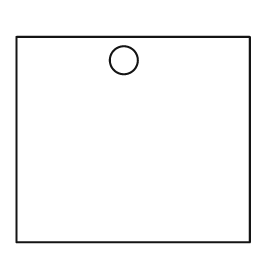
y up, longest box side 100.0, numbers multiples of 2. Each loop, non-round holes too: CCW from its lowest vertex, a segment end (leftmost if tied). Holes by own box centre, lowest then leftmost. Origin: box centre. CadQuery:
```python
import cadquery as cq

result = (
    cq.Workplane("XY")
    .moveTo(-50.0, -44.0)
    .lineTo(50.0, -44.0)
    .lineTo(50.0, 44.0)
    .lineTo(-50.0, 44.0)
    .close()
    .moveTo(-4.0, 34.0)
    .circle(6.0)
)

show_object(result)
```